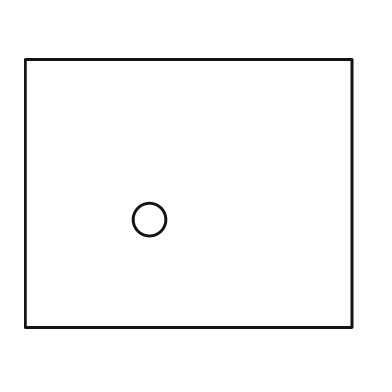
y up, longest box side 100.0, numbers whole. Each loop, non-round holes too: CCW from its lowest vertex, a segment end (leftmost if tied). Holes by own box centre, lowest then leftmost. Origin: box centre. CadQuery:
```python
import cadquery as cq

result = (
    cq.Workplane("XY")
    .moveTo(-50.0, -41.0)
    .lineTo(50.0, -41.0)
    .lineTo(50.0, 41.0)
    .lineTo(-50.0, 41.0)
    .close()
    .moveTo(-12.0, -8.0)
    .circle(5.0)
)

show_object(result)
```